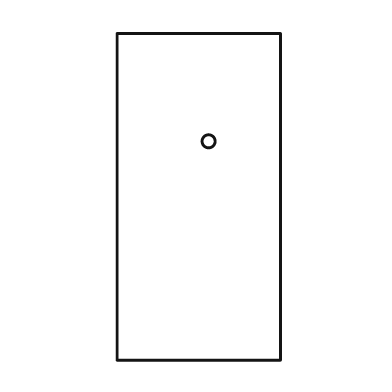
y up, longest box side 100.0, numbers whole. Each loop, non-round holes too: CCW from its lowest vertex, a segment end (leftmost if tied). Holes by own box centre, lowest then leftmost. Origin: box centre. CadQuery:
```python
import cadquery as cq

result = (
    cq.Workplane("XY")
    .moveTo(-25.0, -50.0)
    .lineTo(25.0, -50.0)
    .lineTo(25.0, 50.0)
    .lineTo(-25.0, 50.0)
    .close()
    .moveTo(3.0, 17.0)
    .circle(2.0)
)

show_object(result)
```